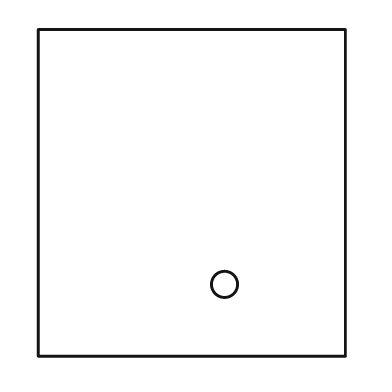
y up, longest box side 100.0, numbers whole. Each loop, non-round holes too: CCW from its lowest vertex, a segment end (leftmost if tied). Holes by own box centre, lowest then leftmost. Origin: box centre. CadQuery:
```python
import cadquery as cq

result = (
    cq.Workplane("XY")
    .moveTo(-47.0, -50.0)
    .lineTo(47.0, -50.0)
    .lineTo(47.0, 50.0)
    .lineTo(-47.0, 50.0)
    .close()
    .moveTo(10.0, -28.0)
    .circle(4.0)
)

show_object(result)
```